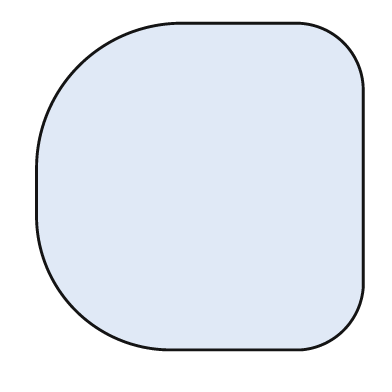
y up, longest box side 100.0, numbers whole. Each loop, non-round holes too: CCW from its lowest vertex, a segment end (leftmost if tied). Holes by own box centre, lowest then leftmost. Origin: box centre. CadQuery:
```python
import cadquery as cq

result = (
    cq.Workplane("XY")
    .moveTo(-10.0, -50.0)
    .lineTo(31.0, -50.0)
    .threePointArc((44.0, -44.0), (50.0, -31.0))
    .lineTo(50.0, 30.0)
    .threePointArc((44.0, 44.0), (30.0, 50.0))
    .lineTo(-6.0, 50.0)
    .threePointArc((-37.0, 37.0), (-50.0, 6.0))
    .lineTo(-50.0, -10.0)
    .threePointArc((-38.0, -38.0), (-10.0, -50.0))
    .close()
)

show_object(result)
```